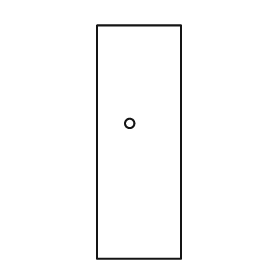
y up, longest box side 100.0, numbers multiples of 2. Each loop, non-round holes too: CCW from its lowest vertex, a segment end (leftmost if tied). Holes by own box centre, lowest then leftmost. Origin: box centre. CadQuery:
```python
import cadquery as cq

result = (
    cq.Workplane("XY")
    .moveTo(-18.0, -50.0)
    .lineTo(18.0, -50.0)
    .lineTo(18.0, 50.0)
    .lineTo(-18.0, 50.0)
    .close()
    .moveTo(-4.0, 8.0)
    .circle(2.0)
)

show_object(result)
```